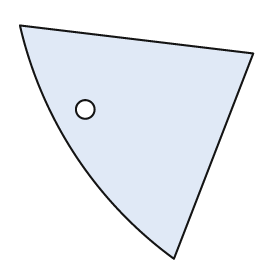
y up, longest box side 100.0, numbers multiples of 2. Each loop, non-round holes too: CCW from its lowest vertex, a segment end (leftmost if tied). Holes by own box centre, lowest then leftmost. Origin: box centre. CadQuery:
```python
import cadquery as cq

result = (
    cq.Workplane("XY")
    .moveTo(16.0, -50.0)
    .lineTo(50.0, 38.0)
    .lineTo(-50.0, 50.0)
    .threePointArc((-26.0, -6.0), (16.0, -50.0))
    .close()
    .moveTo(-22.0, 14.0)
    .circle(4.0)
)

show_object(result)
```